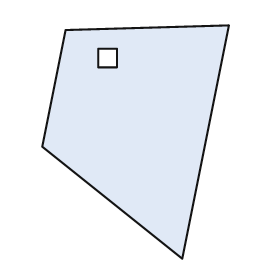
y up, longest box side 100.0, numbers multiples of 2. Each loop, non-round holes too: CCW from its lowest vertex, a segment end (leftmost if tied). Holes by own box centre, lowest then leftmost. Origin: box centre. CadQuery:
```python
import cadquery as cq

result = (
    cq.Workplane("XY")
    .moveTo(20.0, -50.0)
    .lineTo(40.0, 50.0)
    .lineTo(-30.0, 48.0)
    .lineTo(-40.0, -2.0)
    .close()
    .moveTo(-16.0, 32.0)
    .lineTo(-8.0, 32.0)
    .lineTo(-8.0, 40.0)
    .lineTo(-16.0, 40.0)
    .close()
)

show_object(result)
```